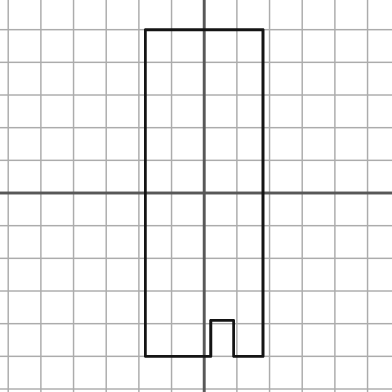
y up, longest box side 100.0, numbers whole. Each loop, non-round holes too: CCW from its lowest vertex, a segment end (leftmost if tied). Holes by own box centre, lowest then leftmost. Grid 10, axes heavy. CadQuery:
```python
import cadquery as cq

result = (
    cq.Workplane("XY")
    .moveTo(-18.0, -50.0)
    .lineTo(2.0, -50.0)
    .lineTo(2.0, -39.0)
    .lineTo(9.0, -39.0)
    .lineTo(9.0, -50.0)
    .lineTo(18.0, -50.0)
    .lineTo(18.0, 50.0)
    .lineTo(-18.0, 50.0)
    .close()
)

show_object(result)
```